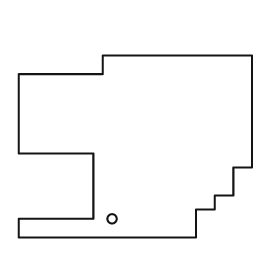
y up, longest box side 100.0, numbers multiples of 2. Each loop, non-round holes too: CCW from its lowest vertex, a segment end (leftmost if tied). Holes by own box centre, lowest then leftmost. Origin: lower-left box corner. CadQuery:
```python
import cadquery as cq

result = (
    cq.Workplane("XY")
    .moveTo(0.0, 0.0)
    .lineTo(76.0, 0.0)
    .lineTo(76.0, 12.0)
    .lineTo(84.0, 12.0)
    .lineTo(84.0, 18.0)
    .lineTo(92.0, 18.0)
    .lineTo(92.0, 30.0)
    .lineTo(100.0, 30.0)
    .lineTo(100.0, 78.0)
    .lineTo(36.0, 78.0)
    .lineTo(36.0, 70.0)
    .lineTo(0.0, 70.0)
    .lineTo(0.0, 36.0)
    .lineTo(32.0, 36.0)
    .lineTo(32.0, 8.0)
    .lineTo(0.0, 8.0)
    .close()
    .moveTo(40.0, 8.0)
    .circle(2.0)
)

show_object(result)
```